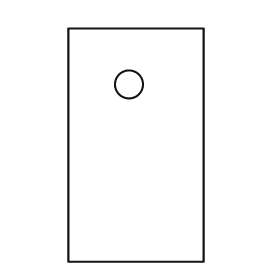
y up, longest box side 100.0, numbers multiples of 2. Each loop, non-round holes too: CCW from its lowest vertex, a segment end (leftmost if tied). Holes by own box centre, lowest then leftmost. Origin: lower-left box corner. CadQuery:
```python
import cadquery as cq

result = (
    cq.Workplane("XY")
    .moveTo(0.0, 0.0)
    .lineTo(58.0, 0.0)
    .lineTo(58.0, 100.0)
    .lineTo(0.0, 100.0)
    .close()
    .moveTo(26.0, 76.0)
    .circle(6.0)
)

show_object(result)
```